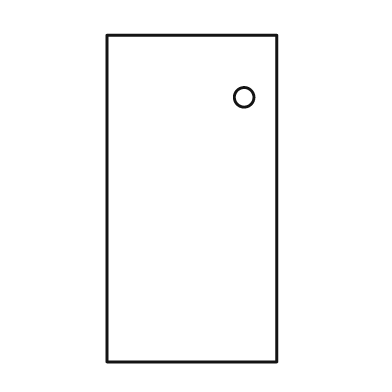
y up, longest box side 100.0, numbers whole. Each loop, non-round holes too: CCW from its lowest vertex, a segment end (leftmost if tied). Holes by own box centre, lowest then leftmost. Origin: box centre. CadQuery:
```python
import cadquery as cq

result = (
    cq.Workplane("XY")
    .moveTo(-26.0, -50.0)
    .lineTo(26.0, -50.0)
    .lineTo(26.0, 50.0)
    .lineTo(-26.0, 50.0)
    .close()
    .moveTo(16.0, 31.0)
    .circle(3.0)
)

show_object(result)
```